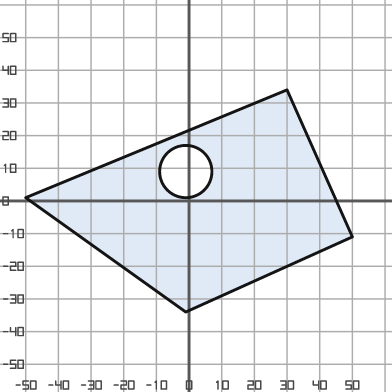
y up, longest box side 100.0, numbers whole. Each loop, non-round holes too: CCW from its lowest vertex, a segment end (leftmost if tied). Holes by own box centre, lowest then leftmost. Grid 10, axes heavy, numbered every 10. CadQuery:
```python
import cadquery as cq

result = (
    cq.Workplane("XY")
    .moveTo(-1.0, -34.0)
    .lineTo(50.0, -11.0)
    .lineTo(30.0, 34.0)
    .lineTo(-50.0, 1.0)
    .close()
    .moveTo(-1.0, 9.0)
    .circle(8.0)
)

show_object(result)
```